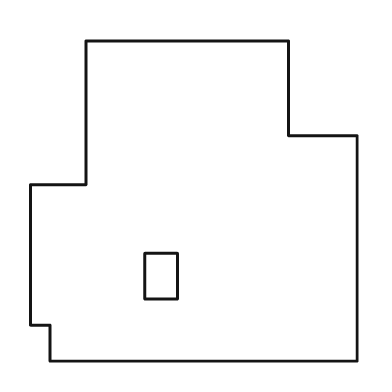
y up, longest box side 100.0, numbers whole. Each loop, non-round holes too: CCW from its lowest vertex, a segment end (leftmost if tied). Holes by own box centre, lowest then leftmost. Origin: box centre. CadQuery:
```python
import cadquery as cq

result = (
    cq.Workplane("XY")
    .moveTo(-44.0, -49.0)
    .lineTo(50.0, -49.0)
    .lineTo(50.0, 20.0)
    .lineTo(29.0, 20.0)
    .lineTo(29.0, 49.0)
    .lineTo(-33.0, 49.0)
    .lineTo(-33.0, 5.0)
    .lineTo(-50.0, 5.0)
    .lineTo(-50.0, -38.0)
    .lineTo(-44.0, -38.0)
    .close()
    .moveTo(-15.0, -30.0)
    .lineTo(-5.0, -30.0)
    .lineTo(-5.0, -16.0)
    .lineTo(-15.0, -16.0)
    .close()
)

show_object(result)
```